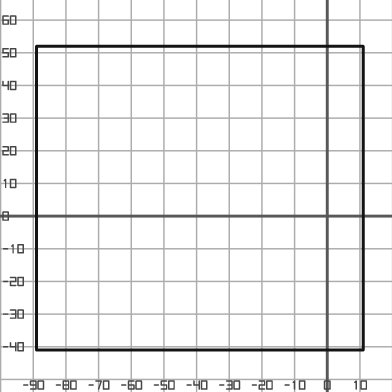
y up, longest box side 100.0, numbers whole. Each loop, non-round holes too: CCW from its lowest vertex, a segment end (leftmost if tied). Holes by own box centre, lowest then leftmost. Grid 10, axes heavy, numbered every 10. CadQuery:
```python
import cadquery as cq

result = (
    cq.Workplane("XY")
    .moveTo(-89.0, -41.0)
    .lineTo(11.0, -41.0)
    .lineTo(11.0, 52.0)
    .lineTo(-89.0, 52.0)
    .close()
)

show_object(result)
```